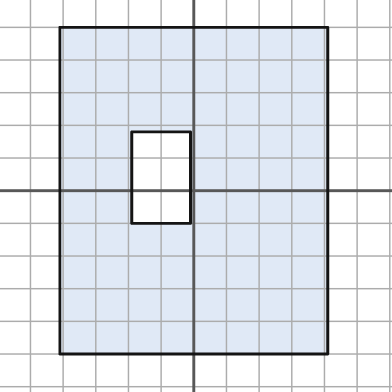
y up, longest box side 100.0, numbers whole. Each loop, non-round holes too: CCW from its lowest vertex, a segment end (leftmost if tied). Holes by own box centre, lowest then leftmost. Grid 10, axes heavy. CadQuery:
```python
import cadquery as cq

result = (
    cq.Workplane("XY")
    .moveTo(-41.0, -50.0)
    .lineTo(41.0, -50.0)
    .lineTo(41.0, 50.0)
    .lineTo(-41.0, 50.0)
    .close()
    .moveTo(-19.0, -10.0)
    .lineTo(-1.0, -10.0)
    .lineTo(-1.0, 18.0)
    .lineTo(-19.0, 18.0)
    .close()
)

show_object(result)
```